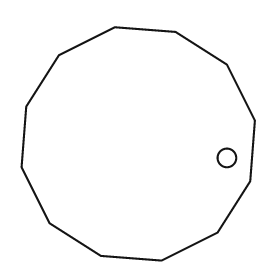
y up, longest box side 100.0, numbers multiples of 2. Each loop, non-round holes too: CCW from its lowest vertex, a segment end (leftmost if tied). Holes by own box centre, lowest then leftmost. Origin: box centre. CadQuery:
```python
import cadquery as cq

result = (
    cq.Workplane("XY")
    .moveTo(10.0, -50.0)
    .lineTo(34.0, -38.0)
    .lineTo(48.0, -16.0)
    .lineTo(50.0, 10.0)
    .lineTo(38.0, 34.0)
    .lineTo(16.0, 48.0)
    .lineTo(-10.0, 50.0)
    .lineTo(-34.0, 38.0)
    .lineTo(-48.0, 16.0)
    .lineTo(-50.0, -10.0)
    .lineTo(-38.0, -34.0)
    .lineTo(-16.0, -48.0)
    .close()
    .moveTo(38.0, -6.0)
    .circle(4.0)
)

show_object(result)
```